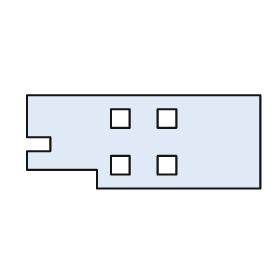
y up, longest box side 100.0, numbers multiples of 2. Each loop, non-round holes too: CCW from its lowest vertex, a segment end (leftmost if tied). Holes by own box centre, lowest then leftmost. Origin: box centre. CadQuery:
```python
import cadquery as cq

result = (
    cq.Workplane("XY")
    .moveTo(-20.0, -20.0)
    .lineTo(50.0, -20.0)
    .lineTo(50.0, 20.0)
    .lineTo(-50.0, 20.0)
    .lineTo(-50.0, 2.0)
    .lineTo(-40.0, 2.0)
    .lineTo(-40.0, -4.0)
    .lineTo(-50.0, -4.0)
    .lineTo(-50.0, -12.0)
    .lineTo(-20.0, -12.0)
    .close()
    .moveTo(-14.0, -14.0)
    .lineTo(-6.0, -14.0)
    .lineTo(-6.0, -6.0)
    .lineTo(-14.0, -6.0)
    .close()
    .moveTo(6.0, -14.0)
    .lineTo(14.0, -14.0)
    .lineTo(14.0, -6.0)
    .lineTo(6.0, -6.0)
    .close()
    .moveTo(-14.0, 6.0)
    .lineTo(-6.0, 6.0)
    .lineTo(-6.0, 14.0)
    .lineTo(-14.0, 14.0)
    .close()
    .moveTo(6.0, 6.0)
    .lineTo(14.0, 6.0)
    .lineTo(14.0, 14.0)
    .lineTo(6.0, 14.0)
    .close()
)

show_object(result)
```